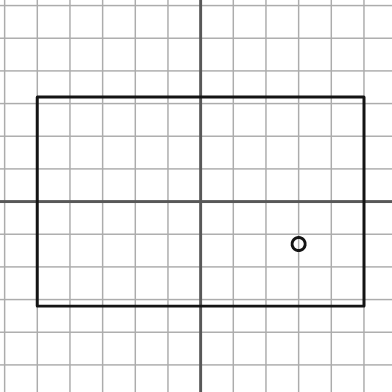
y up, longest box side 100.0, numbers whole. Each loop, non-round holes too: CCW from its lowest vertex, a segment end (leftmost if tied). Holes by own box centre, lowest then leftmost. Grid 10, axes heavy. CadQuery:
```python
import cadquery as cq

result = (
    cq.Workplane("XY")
    .moveTo(-50.0, -32.0)
    .lineTo(50.0, -32.0)
    .lineTo(50.0, 32.0)
    .lineTo(-50.0, 32.0)
    .close()
    .moveTo(30.0, -13.0)
    .circle(2.0)
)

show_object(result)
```